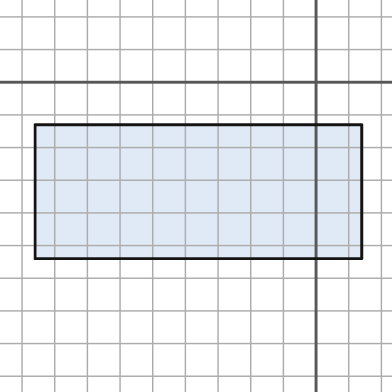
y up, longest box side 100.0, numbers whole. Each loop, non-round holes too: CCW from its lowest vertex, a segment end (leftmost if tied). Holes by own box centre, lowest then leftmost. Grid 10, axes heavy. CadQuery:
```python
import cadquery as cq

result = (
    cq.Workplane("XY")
    .moveTo(-86.0, -54.0)
    .lineTo(14.0, -54.0)
    .lineTo(14.0, -13.0)
    .lineTo(-86.0, -13.0)
    .close()
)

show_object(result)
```